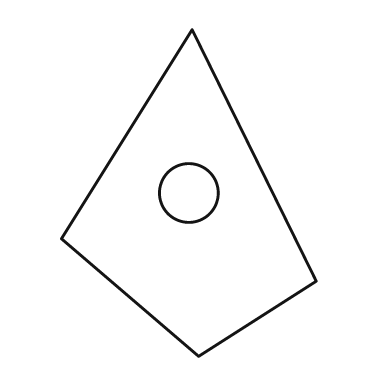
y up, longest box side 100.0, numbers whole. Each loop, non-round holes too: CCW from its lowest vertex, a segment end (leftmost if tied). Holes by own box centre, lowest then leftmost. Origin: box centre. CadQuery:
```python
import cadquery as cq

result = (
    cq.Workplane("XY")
    .moveTo(3.0, -50.0)
    .lineTo(39.0, -27.0)
    .lineTo(1.0, 50.0)
    .lineTo(-39.0, -14.0)
    .close()
    .moveTo(0.0, 0.0)
    .circle(9.0)
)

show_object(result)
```